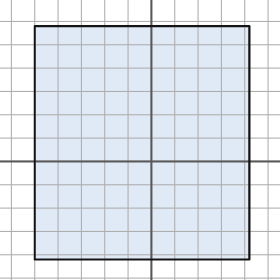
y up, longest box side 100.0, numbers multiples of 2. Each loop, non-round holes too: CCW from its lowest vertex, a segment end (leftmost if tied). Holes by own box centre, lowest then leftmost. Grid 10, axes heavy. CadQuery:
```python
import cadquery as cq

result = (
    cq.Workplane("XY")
    .moveTo(-50.0, -42.0)
    .lineTo(42.0, -42.0)
    .lineTo(42.0, 58.0)
    .lineTo(-50.0, 58.0)
    .close()
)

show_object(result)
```